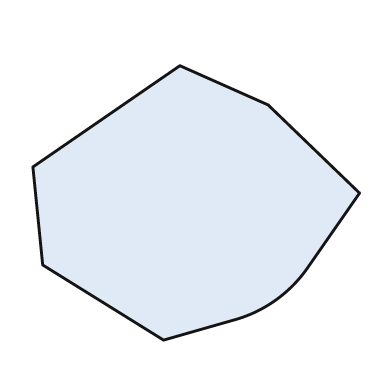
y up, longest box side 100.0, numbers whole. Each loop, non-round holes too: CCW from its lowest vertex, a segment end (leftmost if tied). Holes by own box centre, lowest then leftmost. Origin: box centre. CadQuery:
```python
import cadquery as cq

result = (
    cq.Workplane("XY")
    .moveTo(-10.0, -42.0)
    .lineTo(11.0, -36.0)
    .threePointArc((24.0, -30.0), (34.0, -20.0))
    .lineTo(50.0, 3.0)
    .lineTo(22.0, 30.0)
    .lineTo(-5.0, 42.0)
    .lineTo(-50.0, 11.0)
    .lineTo(-47.0, -19.0)
    .close()
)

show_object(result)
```